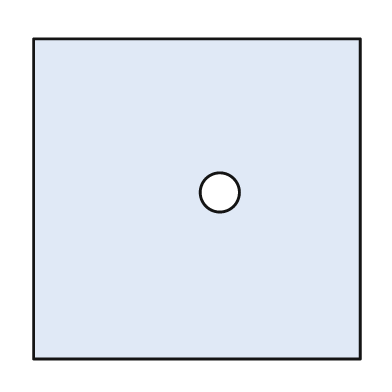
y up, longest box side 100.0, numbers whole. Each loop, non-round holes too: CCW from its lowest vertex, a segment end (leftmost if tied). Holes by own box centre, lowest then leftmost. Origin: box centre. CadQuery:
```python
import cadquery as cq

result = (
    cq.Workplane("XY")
    .moveTo(-50.0, -49.0)
    .lineTo(50.0, -49.0)
    .lineTo(50.0, 49.0)
    .lineTo(-50.0, 49.0)
    .close()
    .moveTo(7.0, 2.0)
    .circle(6.0)
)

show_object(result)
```